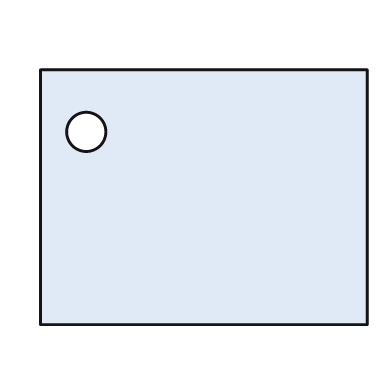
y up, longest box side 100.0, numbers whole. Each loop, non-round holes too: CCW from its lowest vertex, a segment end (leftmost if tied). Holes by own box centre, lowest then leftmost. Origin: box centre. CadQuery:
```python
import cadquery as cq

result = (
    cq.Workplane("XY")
    .moveTo(-50.0, -39.0)
    .lineTo(50.0, -39.0)
    .lineTo(50.0, 39.0)
    .lineTo(-50.0, 39.0)
    .close()
    .moveTo(-36.0, 20.0)
    .circle(6.0)
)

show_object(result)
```